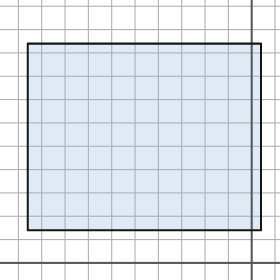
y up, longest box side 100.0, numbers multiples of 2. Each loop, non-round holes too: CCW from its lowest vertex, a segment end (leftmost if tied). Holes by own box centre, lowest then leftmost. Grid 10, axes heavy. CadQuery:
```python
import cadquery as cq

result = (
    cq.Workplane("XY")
    .moveTo(-96.0, 14.0)
    .lineTo(4.0, 14.0)
    .lineTo(4.0, 94.0)
    .lineTo(-96.0, 94.0)
    .close()
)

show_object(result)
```